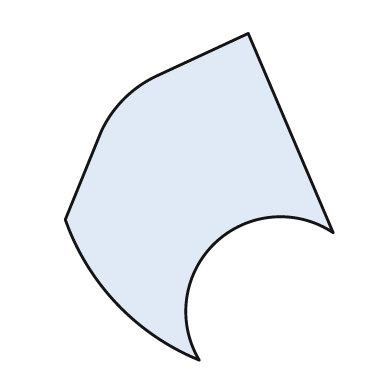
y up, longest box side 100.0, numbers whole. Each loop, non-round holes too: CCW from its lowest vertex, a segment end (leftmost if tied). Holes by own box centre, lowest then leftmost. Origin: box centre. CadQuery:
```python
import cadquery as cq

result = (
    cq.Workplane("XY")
    .moveTo(0.0, -50.0)
    .threePointArc((5.0, -14.0), (41.0, -11.0))
    .lineTo(15.0, 50.0)
    .lineTo(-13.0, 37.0)
    .threePointArc((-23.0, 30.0), (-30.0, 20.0))
    .lineTo(-41.0, -7.0)
    .threePointArc((-25.0, -33.0), (0.0, -50.0))
    .close()
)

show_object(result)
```